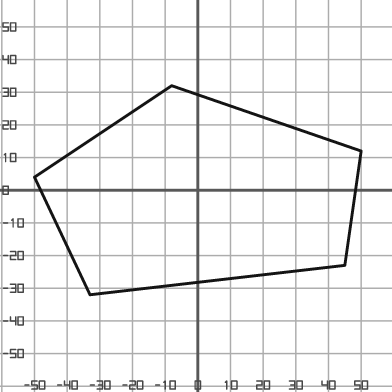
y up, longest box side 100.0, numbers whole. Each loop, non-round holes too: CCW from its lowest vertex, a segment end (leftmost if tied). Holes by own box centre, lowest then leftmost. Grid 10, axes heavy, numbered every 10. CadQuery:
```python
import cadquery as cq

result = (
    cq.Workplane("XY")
    .moveTo(-33.0, -32.0)
    .lineTo(45.0, -23.0)
    .lineTo(50.0, 12.0)
    .lineTo(-8.0, 32.0)
    .lineTo(-50.0, 4.0)
    .close()
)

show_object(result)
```